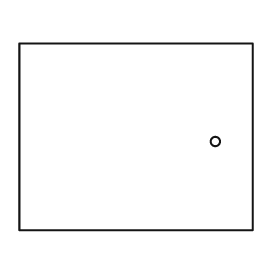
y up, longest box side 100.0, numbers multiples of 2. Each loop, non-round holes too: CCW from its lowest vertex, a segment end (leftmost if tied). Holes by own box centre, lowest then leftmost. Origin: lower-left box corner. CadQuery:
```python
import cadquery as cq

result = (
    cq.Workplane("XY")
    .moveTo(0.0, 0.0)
    .lineTo(100.0, 0.0)
    .lineTo(100.0, 80.0)
    .lineTo(0.0, 80.0)
    .close()
    .moveTo(84.0, 38.0)
    .circle(2.0)
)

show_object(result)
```